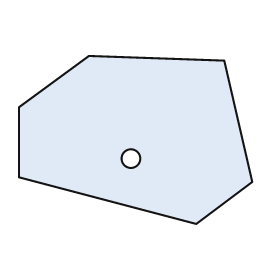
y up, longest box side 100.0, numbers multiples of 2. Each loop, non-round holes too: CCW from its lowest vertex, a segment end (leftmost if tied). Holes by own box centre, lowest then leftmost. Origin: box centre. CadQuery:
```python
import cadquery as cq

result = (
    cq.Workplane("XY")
    .moveTo(26.0, -36.0)
    .lineTo(50.0, -18.0)
    .lineTo(38.0, 34.0)
    .lineTo(-20.0, 36.0)
    .lineTo(-50.0, 14.0)
    .lineTo(-50.0, -16.0)
    .close()
    .moveTo(-2.0, -8.0)
    .circle(4.0)
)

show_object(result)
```